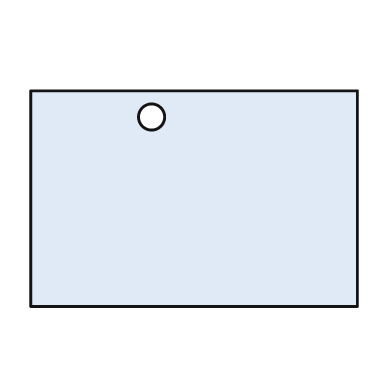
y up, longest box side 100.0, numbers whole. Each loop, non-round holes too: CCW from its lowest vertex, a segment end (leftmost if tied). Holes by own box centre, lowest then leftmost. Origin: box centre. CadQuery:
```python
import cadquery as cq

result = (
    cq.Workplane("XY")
    .moveTo(-50.0, -33.0)
    .lineTo(50.0, -33.0)
    .lineTo(50.0, 33.0)
    .lineTo(-50.0, 33.0)
    .close()
    .moveTo(-13.0, 25.0)
    .circle(4.0)
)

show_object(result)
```